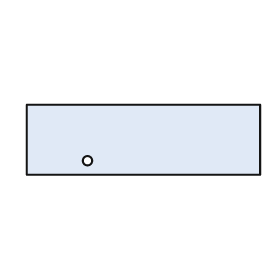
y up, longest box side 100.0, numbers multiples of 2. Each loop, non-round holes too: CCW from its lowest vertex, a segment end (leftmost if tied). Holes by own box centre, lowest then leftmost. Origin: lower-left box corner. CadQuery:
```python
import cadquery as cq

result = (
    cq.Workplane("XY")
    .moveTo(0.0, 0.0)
    .lineTo(100.0, 0.0)
    .lineTo(100.0, 30.0)
    .lineTo(0.0, 30.0)
    .close()
    .moveTo(26.0, 6.0)
    .circle(2.0)
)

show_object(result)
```